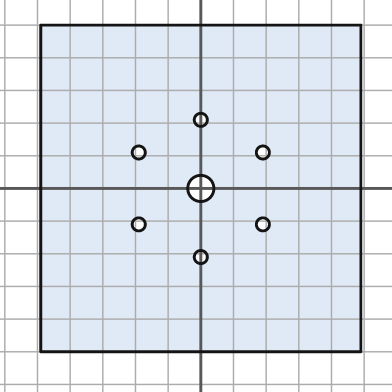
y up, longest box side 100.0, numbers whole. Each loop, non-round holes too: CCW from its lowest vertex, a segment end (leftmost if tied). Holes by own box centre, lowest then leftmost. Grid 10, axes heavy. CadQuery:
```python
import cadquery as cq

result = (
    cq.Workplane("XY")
    .moveTo(-49.0, -50.0)
    .lineTo(49.0, -50.0)
    .lineTo(49.0, 50.0)
    .lineTo(-49.0, 50.0)
    .close()
    .moveTo(0.0, -21.0)
    .circle(2.0)
    .moveTo(-19.0, -11.0)
    .circle(2.0)
    .moveTo(19.0, -11.0)
    .circle(2.0)
    .moveTo(0.0, 0.0)
    .circle(4.0)
    .moveTo(-19.0, 11.0)
    .circle(2.0)
    .moveTo(19.0, 11.0)
    .circle(2.0)
    .moveTo(0.0, 21.0)
    .circle(2.0)
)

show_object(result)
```